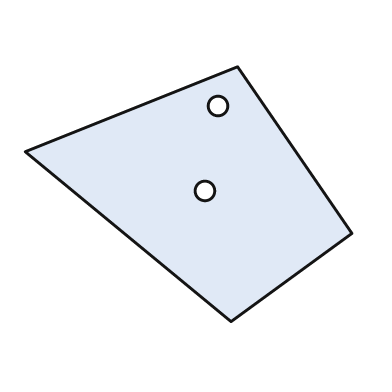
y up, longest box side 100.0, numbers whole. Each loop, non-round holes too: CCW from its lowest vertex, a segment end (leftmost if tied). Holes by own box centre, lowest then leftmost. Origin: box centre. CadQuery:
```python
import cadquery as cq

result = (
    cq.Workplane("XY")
    .moveTo(13.0, -39.0)
    .lineTo(50.0, -12.0)
    .lineTo(15.0, 39.0)
    .lineTo(-50.0, 13.0)
    .close()
    .moveTo(5.0, 1.0)
    .circle(3.0)
    .moveTo(9.0, 27.0)
    .circle(3.0)
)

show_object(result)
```